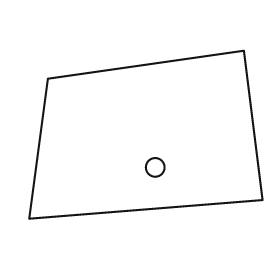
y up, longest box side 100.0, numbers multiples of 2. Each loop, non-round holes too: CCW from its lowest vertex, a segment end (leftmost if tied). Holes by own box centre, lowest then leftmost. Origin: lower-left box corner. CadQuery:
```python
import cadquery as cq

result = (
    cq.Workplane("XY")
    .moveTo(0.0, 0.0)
    .lineTo(100.0, 8.0)
    .lineTo(92.0, 72.0)
    .lineTo(8.0, 60.0)
    .close()
    .moveTo(54.0, 22.0)
    .circle(4.0)
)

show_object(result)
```